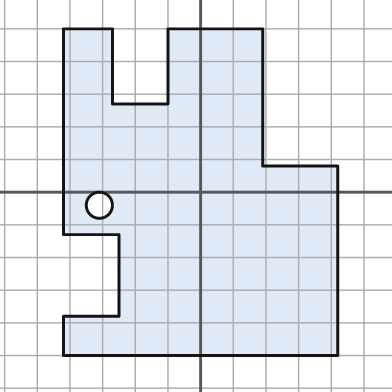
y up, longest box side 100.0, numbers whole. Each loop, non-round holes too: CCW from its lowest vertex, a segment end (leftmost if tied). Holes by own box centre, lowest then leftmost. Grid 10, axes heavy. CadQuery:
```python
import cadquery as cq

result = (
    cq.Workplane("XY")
    .moveTo(-42.0, -50.0)
    .lineTo(42.0, -50.0)
    .lineTo(42.0, 8.0)
    .lineTo(19.0, 8.0)
    .lineTo(19.0, 50.0)
    .lineTo(-10.0, 50.0)
    .lineTo(-10.0, 27.0)
    .lineTo(-27.0, 27.0)
    .lineTo(-27.0, 50.0)
    .lineTo(-42.0, 50.0)
    .lineTo(-42.0, -13.0)
    .lineTo(-25.0, -13.0)
    .lineTo(-25.0, -38.0)
    .lineTo(-42.0, -38.0)
    .close()
    .moveTo(-31.0, -4.0)
    .circle(4.0)
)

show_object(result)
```